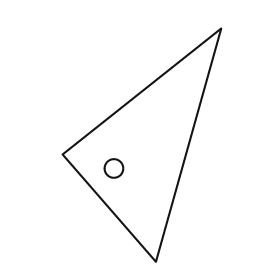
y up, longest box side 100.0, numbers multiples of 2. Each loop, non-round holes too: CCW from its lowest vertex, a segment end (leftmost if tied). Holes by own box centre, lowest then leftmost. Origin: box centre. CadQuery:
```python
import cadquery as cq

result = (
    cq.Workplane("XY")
    .moveTo(6.0, -50.0)
    .lineTo(34.0, 50.0)
    .lineTo(-34.0, -4.0)
    .close()
    .moveTo(-12.0, -10.0)
    .circle(4.0)
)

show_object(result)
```